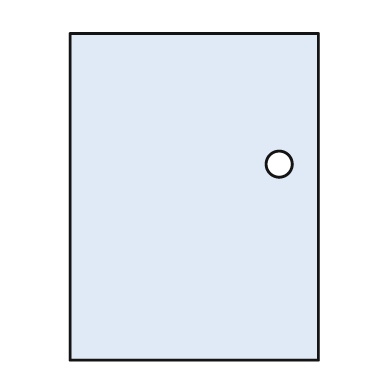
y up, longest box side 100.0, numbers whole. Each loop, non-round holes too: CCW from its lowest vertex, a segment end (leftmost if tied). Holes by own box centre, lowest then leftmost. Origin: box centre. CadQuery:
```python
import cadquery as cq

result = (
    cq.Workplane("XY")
    .moveTo(-38.0, -50.0)
    .lineTo(38.0, -50.0)
    .lineTo(38.0, 50.0)
    .lineTo(-38.0, 50.0)
    .close()
    .moveTo(26.0, 10.0)
    .circle(4.0)
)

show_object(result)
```